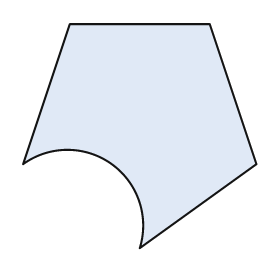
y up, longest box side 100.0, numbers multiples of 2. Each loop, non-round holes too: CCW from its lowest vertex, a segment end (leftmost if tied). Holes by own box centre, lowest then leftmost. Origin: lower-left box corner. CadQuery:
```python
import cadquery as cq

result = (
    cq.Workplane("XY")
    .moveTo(50.0, 0.0)
    .lineTo(100.0, 36.0)
    .lineTo(80.0, 96.0)
    .lineTo(20.0, 96.0)
    .lineTo(0.0, 36.0)
    .threePointArc((38.0, 36.0), (50.0, 0.0))
    .close()
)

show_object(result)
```